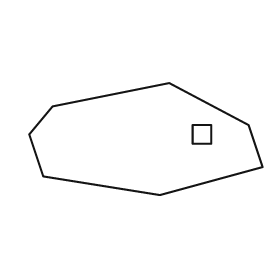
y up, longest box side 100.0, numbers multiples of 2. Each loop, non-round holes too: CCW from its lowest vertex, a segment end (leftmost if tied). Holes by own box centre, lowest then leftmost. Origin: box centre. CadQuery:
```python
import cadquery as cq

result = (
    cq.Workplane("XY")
    .moveTo(6.0, -24.0)
    .lineTo(50.0, -12.0)
    .lineTo(44.0, 6.0)
    .lineTo(10.0, 24.0)
    .lineTo(-40.0, 14.0)
    .lineTo(-50.0, 2.0)
    .lineTo(-44.0, -16.0)
    .close()
    .moveTo(20.0, -2.0)
    .lineTo(28.0, -2.0)
    .lineTo(28.0, 6.0)
    .lineTo(20.0, 6.0)
    .close()
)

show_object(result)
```